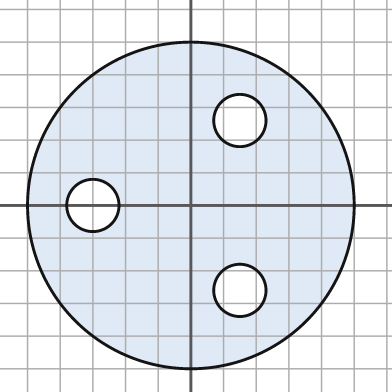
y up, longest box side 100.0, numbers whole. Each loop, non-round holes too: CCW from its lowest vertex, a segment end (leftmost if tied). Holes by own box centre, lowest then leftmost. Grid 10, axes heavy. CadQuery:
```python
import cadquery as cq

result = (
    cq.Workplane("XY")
    .moveTo(0.0, 0.0)
    .circle(50.0)
    .moveTo(15.0, -26.0)
    .circle(8.0)
    .moveTo(-30.0, 0.0)
    .circle(8.0)
    .moveTo(15.0, 26.0)
    .circle(8.0)
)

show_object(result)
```